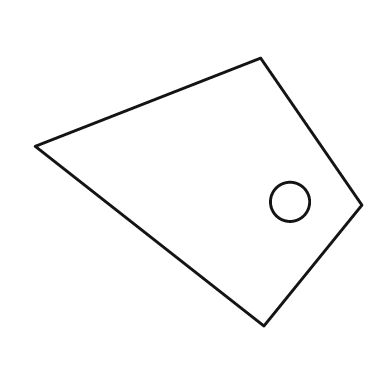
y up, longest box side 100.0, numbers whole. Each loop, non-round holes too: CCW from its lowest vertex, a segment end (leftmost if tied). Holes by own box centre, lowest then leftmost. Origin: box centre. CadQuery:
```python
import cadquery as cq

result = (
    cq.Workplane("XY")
    .moveTo(20.0, -41.0)
    .lineTo(50.0, -4.0)
    .lineTo(19.0, 41.0)
    .lineTo(-50.0, 14.0)
    .close()
    .moveTo(28.0, -3.0)
    .circle(6.0)
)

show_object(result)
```